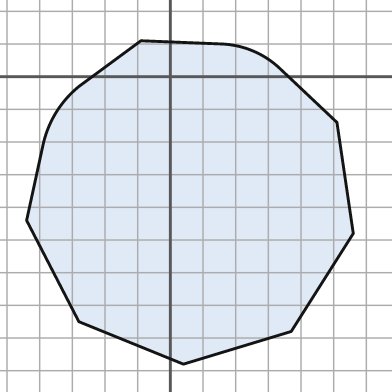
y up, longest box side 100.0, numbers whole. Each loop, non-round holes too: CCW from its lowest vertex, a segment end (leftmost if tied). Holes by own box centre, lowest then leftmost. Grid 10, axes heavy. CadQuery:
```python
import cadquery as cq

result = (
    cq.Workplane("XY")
    .moveTo(4.0, -88.0)
    .lineTo(37.0, -78.0)
    .lineTo(56.0, -48.0)
    .lineTo(51.0, -14.0)
    .lineTo(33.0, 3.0)
    .threePointArc((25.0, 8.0), (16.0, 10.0))
    .lineTo(-9.0, 11.0)
    .lineTo(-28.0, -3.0)
    .threePointArc((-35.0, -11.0), (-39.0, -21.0))
    .lineTo(-44.0, -44.0)
    .lineTo(-28.0, -75.0)
    .close()
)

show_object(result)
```